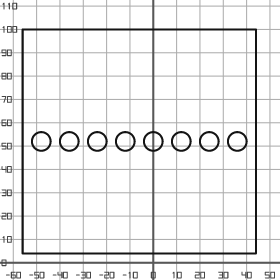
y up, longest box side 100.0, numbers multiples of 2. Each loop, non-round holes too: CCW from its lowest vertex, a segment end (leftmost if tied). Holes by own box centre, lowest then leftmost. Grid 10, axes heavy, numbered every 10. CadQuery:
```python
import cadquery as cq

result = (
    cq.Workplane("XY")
    .moveTo(-56.0, 4.0)
    .lineTo(44.0, 4.0)
    .lineTo(44.0, 100.0)
    .lineTo(-56.0, 100.0)
    .close()
    .moveTo(-48.0, 52.0)
    .circle(4.0)
    .moveTo(-36.0, 52.0)
    .circle(4.0)
    .moveTo(-24.0, 52.0)
    .circle(4.0)
    .moveTo(-12.0, 52.0)
    .circle(4.0)
    .moveTo(0.0, 52.0)
    .circle(4.0)
    .moveTo(12.0, 52.0)
    .circle(4.0)
    .moveTo(24.0, 52.0)
    .circle(4.0)
    .moveTo(36.0, 52.0)
    .circle(4.0)
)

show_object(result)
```